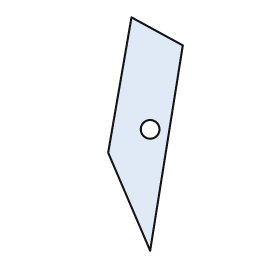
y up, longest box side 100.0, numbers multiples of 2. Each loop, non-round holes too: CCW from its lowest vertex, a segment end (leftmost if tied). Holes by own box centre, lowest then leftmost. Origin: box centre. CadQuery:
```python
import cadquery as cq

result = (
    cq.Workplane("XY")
    .moveTo(2.0, -50.0)
    .lineTo(16.0, 38.0)
    .lineTo(-6.0, 50.0)
    .lineTo(-16.0, -8.0)
    .close()
    .moveTo(2.0, 2.0)
    .circle(4.0)
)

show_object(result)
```